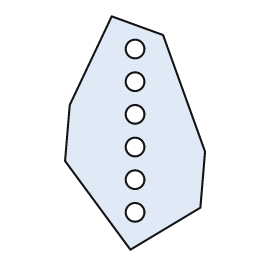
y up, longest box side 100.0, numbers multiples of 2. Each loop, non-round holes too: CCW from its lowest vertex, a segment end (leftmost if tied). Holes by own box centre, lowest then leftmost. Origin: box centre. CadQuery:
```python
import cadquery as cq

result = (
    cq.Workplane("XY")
    .moveTo(-2.0, -50.0)
    .lineTo(28.0, -32.0)
    .lineTo(30.0, -8.0)
    .lineTo(12.0, 42.0)
    .lineTo(-10.0, 50.0)
    .lineTo(-28.0, 12.0)
    .lineTo(-30.0, -12.0)
    .close()
    .moveTo(0.0, -34.0)
    .circle(4.0)
    .moveTo(0.0, -20.0)
    .circle(4.0)
    .moveTo(0.0, -6.0)
    .circle(4.0)
    .moveTo(0.0, 8.0)
    .circle(4.0)
    .moveTo(0.0, 22.0)
    .circle(4.0)
    .moveTo(0.0, 36.0)
    .circle(4.0)
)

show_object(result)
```